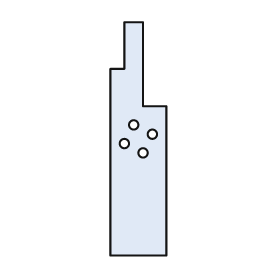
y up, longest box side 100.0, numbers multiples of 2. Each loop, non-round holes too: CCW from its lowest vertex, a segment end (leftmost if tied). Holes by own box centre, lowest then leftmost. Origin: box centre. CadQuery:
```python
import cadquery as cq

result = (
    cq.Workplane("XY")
    .moveTo(-12.0, -50.0)
    .lineTo(12.0, -50.0)
    .lineTo(12.0, 14.0)
    .lineTo(2.0, 14.0)
    .lineTo(2.0, 50.0)
    .lineTo(-6.0, 50.0)
    .lineTo(-6.0, 30.0)
    .lineTo(-12.0, 30.0)
    .close()
    .moveTo(2.0, -6.0)
    .circle(2.0)
    .moveTo(-6.0, -2.0)
    .circle(2.0)
    .moveTo(6.0, 2.0)
    .circle(2.0)
    .moveTo(-2.0, 6.0)
    .circle(2.0)
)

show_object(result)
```